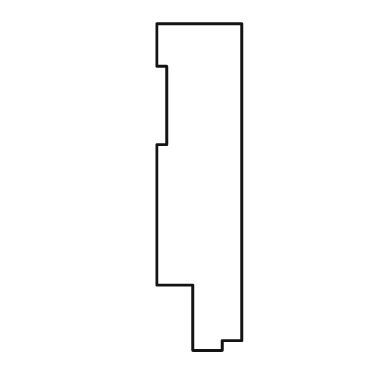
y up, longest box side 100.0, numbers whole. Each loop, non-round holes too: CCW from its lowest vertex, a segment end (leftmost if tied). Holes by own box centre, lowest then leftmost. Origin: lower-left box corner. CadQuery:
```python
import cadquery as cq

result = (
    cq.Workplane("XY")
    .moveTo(11.0, 0.0)
    .lineTo(20.0, 0.0)
    .lineTo(20.0, 3.0)
    .lineTo(26.0, 3.0)
    .lineTo(26.0, 100.0)
    .lineTo(0.0, 100.0)
    .lineTo(0.0, 87.0)
    .lineTo(3.0, 87.0)
    .lineTo(3.0, 63.0)
    .lineTo(0.0, 63.0)
    .lineTo(0.0, 20.0)
    .lineTo(11.0, 20.0)
    .close()
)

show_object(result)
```